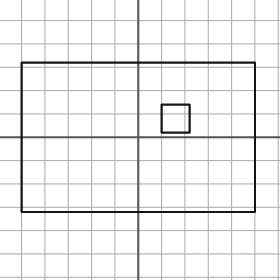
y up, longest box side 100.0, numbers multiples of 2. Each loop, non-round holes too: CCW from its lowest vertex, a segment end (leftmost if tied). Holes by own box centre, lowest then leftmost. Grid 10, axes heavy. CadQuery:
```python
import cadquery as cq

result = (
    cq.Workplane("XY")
    .moveTo(-50.0, -32.0)
    .lineTo(50.0, -32.0)
    .lineTo(50.0, 32.0)
    .lineTo(-50.0, 32.0)
    .close()
    .moveTo(10.0, 2.0)
    .lineTo(22.0, 2.0)
    .lineTo(22.0, 14.0)
    .lineTo(10.0, 14.0)
    .close()
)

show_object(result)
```